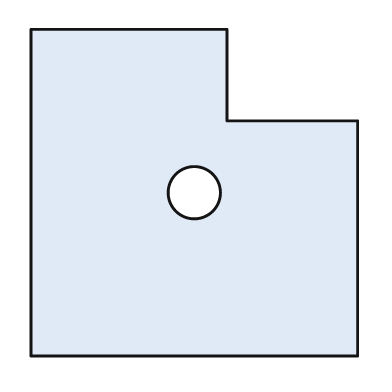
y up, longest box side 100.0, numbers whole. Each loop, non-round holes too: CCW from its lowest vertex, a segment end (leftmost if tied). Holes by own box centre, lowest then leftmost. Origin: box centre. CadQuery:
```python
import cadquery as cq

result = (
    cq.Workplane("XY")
    .moveTo(-50.0, -50.0)
    .lineTo(50.0, -50.0)
    .lineTo(50.0, 22.0)
    .lineTo(10.0, 22.0)
    .lineTo(10.0, 50.0)
    .lineTo(-50.0, 50.0)
    .close()
    .moveTo(0.0, 0.0)
    .circle(8.0)
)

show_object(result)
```